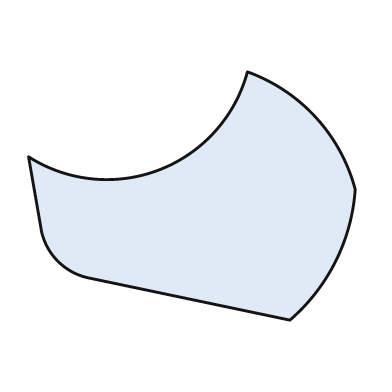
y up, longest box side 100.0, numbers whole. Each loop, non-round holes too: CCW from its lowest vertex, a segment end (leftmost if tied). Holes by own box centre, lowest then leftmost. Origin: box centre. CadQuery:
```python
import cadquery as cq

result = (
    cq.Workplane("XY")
    .moveTo(30.0, -38.0)
    .threePointArc((44.0, -20.0), (50.0, 2.0))
    .threePointArc((38.0, 24.0), (17.0, 38.0))
    .threePointArc((-10.0, 8.0), (-50.0, 12.0))
    .lineTo(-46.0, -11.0)
    .threePointArc((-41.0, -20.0), (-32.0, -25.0))
    .close()
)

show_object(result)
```